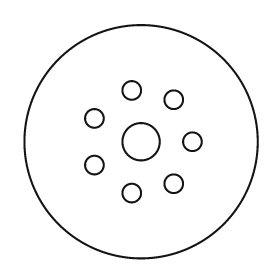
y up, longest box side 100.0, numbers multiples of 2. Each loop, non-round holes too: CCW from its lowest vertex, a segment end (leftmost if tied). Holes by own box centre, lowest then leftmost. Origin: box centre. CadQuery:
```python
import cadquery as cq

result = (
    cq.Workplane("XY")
    .moveTo(0.0, 0.0)
    .circle(50.0)
    .moveTo(-4.0, -22.0)
    .circle(4.0)
    .moveTo(14.0, -18.0)
    .circle(4.0)
    .moveTo(-20.0, -10.0)
    .circle(4.0)
    .moveTo(0.0, 0.0)
    .circle(8.0)
    .moveTo(22.0, 0.0)
    .circle(4.0)
    .moveTo(-20.0, 10.0)
    .circle(4.0)
    .moveTo(14.0, 18.0)
    .circle(4.0)
    .moveTo(-4.0, 22.0)
    .circle(4.0)
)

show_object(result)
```